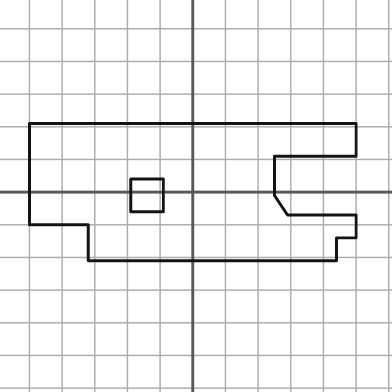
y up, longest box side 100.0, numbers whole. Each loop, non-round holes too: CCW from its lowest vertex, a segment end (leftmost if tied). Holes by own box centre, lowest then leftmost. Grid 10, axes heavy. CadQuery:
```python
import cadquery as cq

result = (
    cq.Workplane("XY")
    .moveTo(-32.0, -21.0)
    .lineTo(44.0, -21.0)
    .lineTo(44.0, -14.0)
    .lineTo(50.0, -14.0)
    .lineTo(50.0, -7.0)
    .lineTo(29.0, -7.0)
    .lineTo(25.0, -1.0)
    .lineTo(25.0, 11.0)
    .lineTo(50.0, 11.0)
    .lineTo(50.0, 21.0)
    .lineTo(-50.0, 21.0)
    .lineTo(-50.0, -10.0)
    .lineTo(-32.0, -10.0)
    .close()
    .moveTo(-19.0, -6.0)
    .lineTo(-9.0, -6.0)
    .lineTo(-9.0, 4.0)
    .lineTo(-19.0, 4.0)
    .close()
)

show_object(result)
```